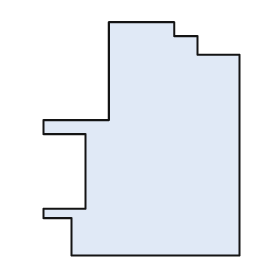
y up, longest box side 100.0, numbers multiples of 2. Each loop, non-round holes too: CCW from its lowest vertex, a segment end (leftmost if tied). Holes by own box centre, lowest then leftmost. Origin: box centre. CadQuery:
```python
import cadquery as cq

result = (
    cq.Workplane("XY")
    .moveTo(-30.0, -50.0)
    .lineTo(42.0, -50.0)
    .lineTo(42.0, 36.0)
    .lineTo(24.0, 36.0)
    .lineTo(24.0, 44.0)
    .lineTo(14.0, 44.0)
    .lineTo(14.0, 50.0)
    .lineTo(-14.0, 50.0)
    .lineTo(-14.0, 8.0)
    .lineTo(-42.0, 8.0)
    .lineTo(-42.0, 2.0)
    .lineTo(-24.0, 2.0)
    .lineTo(-24.0, -30.0)
    .lineTo(-42.0, -30.0)
    .lineTo(-42.0, -34.0)
    .lineTo(-30.0, -34.0)
    .close()
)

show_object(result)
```